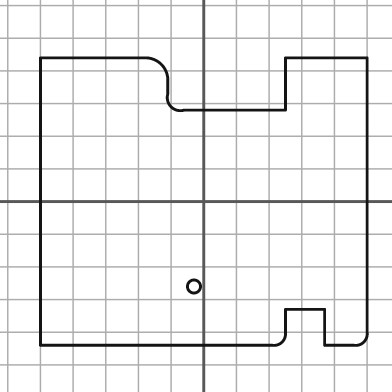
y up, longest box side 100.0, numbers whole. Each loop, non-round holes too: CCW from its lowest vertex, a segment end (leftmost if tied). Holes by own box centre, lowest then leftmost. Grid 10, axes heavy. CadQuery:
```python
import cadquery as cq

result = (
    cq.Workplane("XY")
    .moveTo(-50.0, -44.0)
    .lineTo(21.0, -44.0)
    .threePointArc((24.0, -43.0), (25.0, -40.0))
    .lineTo(25.0, -33.0)
    .lineTo(37.0, -33.0)
    .lineTo(37.0, -44.0)
    .lineTo(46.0, -44.0)
    .threePointArc((49.0, -43.0), (50.0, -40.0))
    .lineTo(50.0, 44.0)
    .lineTo(25.0, 44.0)
    .lineTo(25.0, 28.0)
    .lineTo(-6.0, 28.0)
    .threePointArc((-10.0, 29.0), (-11.0, 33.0))
    .lineTo(-11.0, 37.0)
    .threePointArc((-13.0, 42.0), (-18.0, 44.0))
    .lineTo(-50.0, 44.0)
    .close()
    .moveTo(-3.0, -26.0)
    .circle(2.0)
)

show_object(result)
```